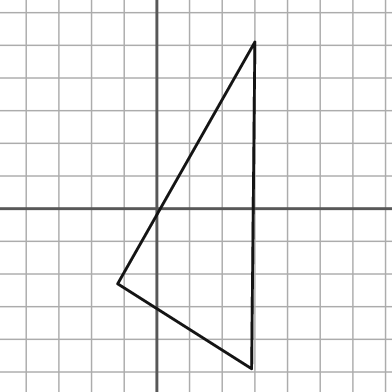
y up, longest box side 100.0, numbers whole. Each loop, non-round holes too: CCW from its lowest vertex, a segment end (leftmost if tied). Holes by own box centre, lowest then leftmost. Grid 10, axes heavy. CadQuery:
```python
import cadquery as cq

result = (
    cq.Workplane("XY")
    .moveTo(29.0, -49.0)
    .lineTo(30.0, 51.0)
    .lineTo(-12.0, -23.0)
    .close()
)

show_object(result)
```